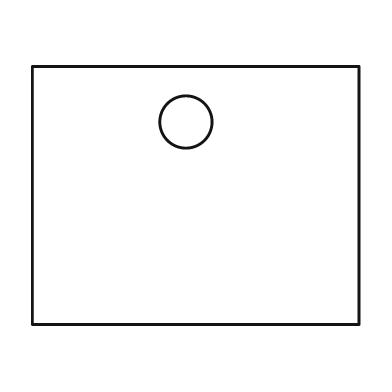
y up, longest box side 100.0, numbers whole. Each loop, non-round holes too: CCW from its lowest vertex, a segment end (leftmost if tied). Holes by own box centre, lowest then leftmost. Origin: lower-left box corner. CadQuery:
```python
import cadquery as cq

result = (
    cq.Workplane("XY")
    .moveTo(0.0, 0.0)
    .lineTo(100.0, 0.0)
    .lineTo(100.0, 79.0)
    .lineTo(0.0, 79.0)
    .close()
    .moveTo(47.0, 62.0)
    .circle(8.0)
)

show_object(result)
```